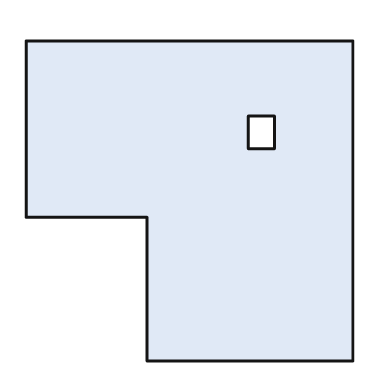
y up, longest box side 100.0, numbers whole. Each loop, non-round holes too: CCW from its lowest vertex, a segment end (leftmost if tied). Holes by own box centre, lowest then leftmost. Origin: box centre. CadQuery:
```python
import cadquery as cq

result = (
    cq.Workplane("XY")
    .moveTo(-13.0, -49.0)
    .lineTo(50.0, -49.0)
    .lineTo(50.0, 49.0)
    .lineTo(-50.0, 49.0)
    .lineTo(-50.0, -5.0)
    .lineTo(-13.0, -5.0)
    .close()
    .moveTo(18.0, 16.0)
    .lineTo(26.0, 16.0)
    .lineTo(26.0, 26.0)
    .lineTo(18.0, 26.0)
    .close()
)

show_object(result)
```